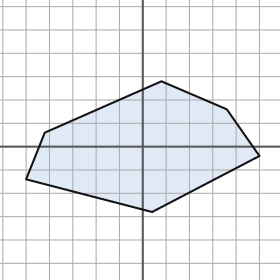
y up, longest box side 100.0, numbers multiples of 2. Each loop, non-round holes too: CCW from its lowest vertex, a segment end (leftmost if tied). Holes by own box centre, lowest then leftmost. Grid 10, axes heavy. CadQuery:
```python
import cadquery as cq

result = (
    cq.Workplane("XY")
    .moveTo(4.0, -28.0)
    .lineTo(50.0, -4.0)
    .lineTo(36.0, 16.0)
    .lineTo(8.0, 28.0)
    .lineTo(-42.0, 6.0)
    .lineTo(-50.0, -14.0)
    .close()
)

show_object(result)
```